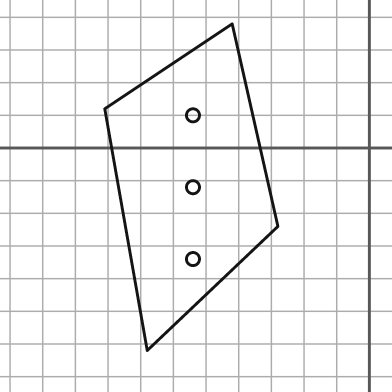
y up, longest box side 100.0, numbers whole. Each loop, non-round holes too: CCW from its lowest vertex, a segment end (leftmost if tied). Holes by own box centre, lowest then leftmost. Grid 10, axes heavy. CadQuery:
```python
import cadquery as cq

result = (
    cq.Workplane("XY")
    .moveTo(-68.0, -62.0)
    .lineTo(-28.0, -24.0)
    .lineTo(-42.0, 38.0)
    .lineTo(-81.0, 12.0)
    .close()
    .moveTo(-54.0, -34.0)
    .circle(2.0)
    .moveTo(-54.0, -12.0)
    .circle(2.0)
    .moveTo(-54.0, 10.0)
    .circle(2.0)
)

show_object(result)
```